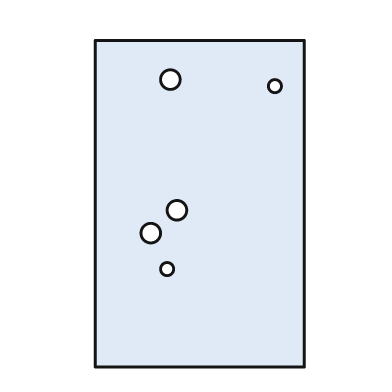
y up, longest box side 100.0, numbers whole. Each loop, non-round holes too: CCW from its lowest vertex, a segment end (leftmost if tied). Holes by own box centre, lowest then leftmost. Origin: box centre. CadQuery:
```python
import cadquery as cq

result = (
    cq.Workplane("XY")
    .moveTo(-32.0, -50.0)
    .lineTo(32.0, -50.0)
    .lineTo(32.0, 50.0)
    .lineTo(-32.0, 50.0)
    .close()
    .moveTo(-10.0, -20.0)
    .circle(2.0)
    .moveTo(-15.0, -9.0)
    .circle(3.0)
    .moveTo(-7.0, -2.0)
    .circle(3.0)
    .moveTo(23.0, 36.0)
    .circle(2.0)
    .moveTo(-9.0, 38.0)
    .circle(3.0)
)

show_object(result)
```